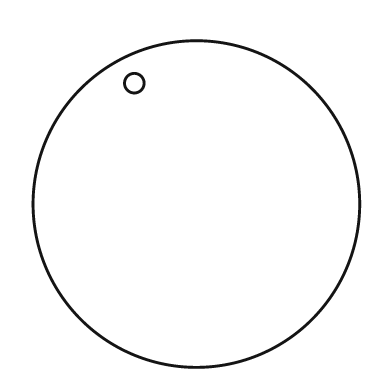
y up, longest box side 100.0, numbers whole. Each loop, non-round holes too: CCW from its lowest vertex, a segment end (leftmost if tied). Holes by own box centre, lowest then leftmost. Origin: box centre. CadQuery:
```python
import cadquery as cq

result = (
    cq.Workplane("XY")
    .moveTo(0.0, 0.0)
    .circle(50.0)
    .moveTo(-19.0, 37.0)
    .circle(3.0)
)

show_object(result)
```